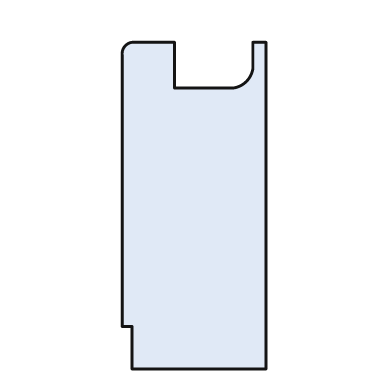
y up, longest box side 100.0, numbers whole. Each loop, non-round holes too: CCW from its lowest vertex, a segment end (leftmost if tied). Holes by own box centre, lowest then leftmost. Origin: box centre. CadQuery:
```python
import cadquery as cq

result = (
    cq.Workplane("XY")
    .moveTo(-19.0, -50.0)
    .lineTo(22.0, -50.0)
    .lineTo(22.0, 50.0)
    .lineTo(18.0, 50.0)
    .lineTo(18.0, 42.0)
    .threePointArc((16.0, 38.0), (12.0, 36.0))
    .lineTo(-6.0, 36.0)
    .lineTo(-6.0, 50.0)
    .lineTo(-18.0, 50.0)
    .threePointArc((-21.0, 49.0), (-22.0, 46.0))
    .lineTo(-22.0, -37.0)
    .lineTo(-19.0, -37.0)
    .close()
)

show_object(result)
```